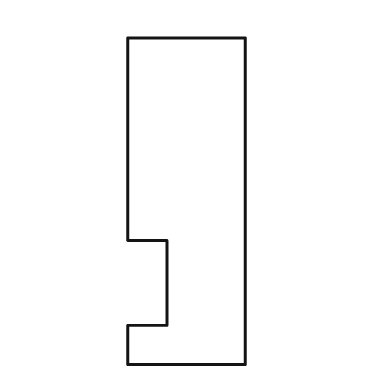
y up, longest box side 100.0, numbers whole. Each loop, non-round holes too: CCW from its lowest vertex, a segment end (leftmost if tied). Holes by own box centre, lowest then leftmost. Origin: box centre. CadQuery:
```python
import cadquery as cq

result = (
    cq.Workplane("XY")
    .moveTo(-18.0, -50.0)
    .lineTo(18.0, -50.0)
    .lineTo(18.0, 50.0)
    .lineTo(-18.0, 50.0)
    .lineTo(-18.0, -12.0)
    .lineTo(-6.0, -12.0)
    .lineTo(-6.0, -38.0)
    .lineTo(-18.0, -38.0)
    .close()
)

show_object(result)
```